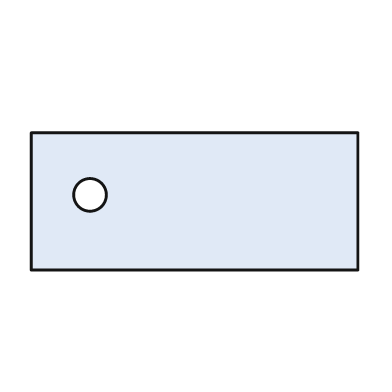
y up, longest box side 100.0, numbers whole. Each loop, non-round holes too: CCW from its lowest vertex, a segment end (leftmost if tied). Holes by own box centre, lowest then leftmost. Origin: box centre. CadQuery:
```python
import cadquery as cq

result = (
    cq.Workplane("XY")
    .moveTo(-50.0, -21.0)
    .lineTo(50.0, -21.0)
    .lineTo(50.0, 21.0)
    .lineTo(-50.0, 21.0)
    .close()
    .moveTo(-32.0, 2.0)
    .circle(5.0)
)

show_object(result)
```